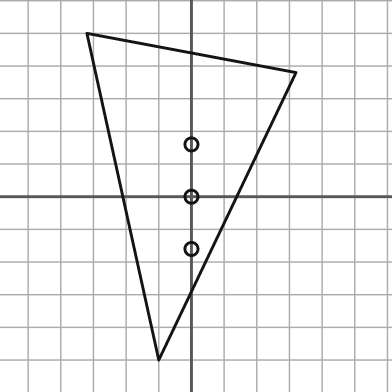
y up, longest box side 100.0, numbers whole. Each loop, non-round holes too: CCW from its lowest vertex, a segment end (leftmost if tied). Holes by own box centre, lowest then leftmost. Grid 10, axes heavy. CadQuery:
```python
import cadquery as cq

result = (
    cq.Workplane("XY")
    .moveTo(-10.0, -50.0)
    .lineTo(32.0, 38.0)
    .lineTo(-32.0, 50.0)
    .close()
    .moveTo(0.0, -16.0)
    .circle(2.0)
    .moveTo(0.0, 0.0)
    .circle(2.0)
    .moveTo(0.0, 16.0)
    .circle(2.0)
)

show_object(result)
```